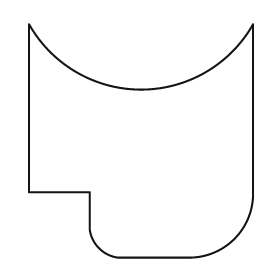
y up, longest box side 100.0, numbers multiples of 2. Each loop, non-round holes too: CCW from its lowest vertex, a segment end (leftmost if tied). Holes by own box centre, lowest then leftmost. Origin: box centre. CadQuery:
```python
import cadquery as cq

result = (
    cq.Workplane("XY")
    .moveTo(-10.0, -50.0)
    .lineTo(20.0, -50.0)
    .threePointArc((40.0, -42.0), (48.0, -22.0))
    .lineTo(48.0, 50.0)
    .threePointArc((0.0, 22.0), (-48.0, 50.0))
    .lineTo(-48.0, -22.0)
    .lineTo(-22.0, -22.0)
    .lineTo(-22.0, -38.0)
    .threePointArc((-18.0, -46.0), (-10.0, -50.0))
    .close()
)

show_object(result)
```